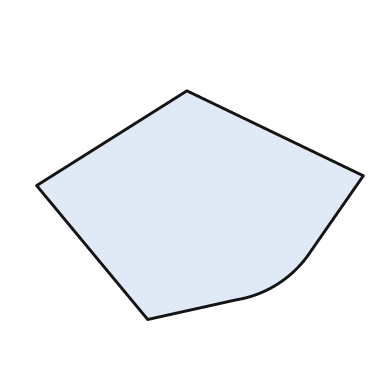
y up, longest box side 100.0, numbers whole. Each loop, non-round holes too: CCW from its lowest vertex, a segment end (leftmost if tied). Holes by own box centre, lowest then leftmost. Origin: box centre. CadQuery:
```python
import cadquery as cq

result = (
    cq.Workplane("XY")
    .moveTo(-16.0, -35.0)
    .lineTo(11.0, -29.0)
    .threePointArc((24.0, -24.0), (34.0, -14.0))
    .lineTo(50.0, 9.0)
    .lineTo(-4.0, 35.0)
    .lineTo(-50.0, 6.0)
    .close()
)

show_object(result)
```